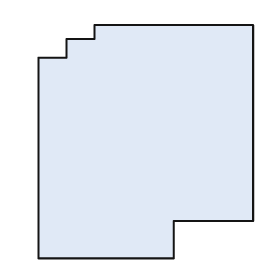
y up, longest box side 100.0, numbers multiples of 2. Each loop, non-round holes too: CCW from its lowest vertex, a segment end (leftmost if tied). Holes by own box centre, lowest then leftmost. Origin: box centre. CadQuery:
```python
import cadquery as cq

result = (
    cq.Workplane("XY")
    .moveTo(-46.0, -50.0)
    .lineTo(12.0, -50.0)
    .lineTo(12.0, -34.0)
    .lineTo(46.0, -34.0)
    .lineTo(46.0, 50.0)
    .lineTo(-22.0, 50.0)
    .lineTo(-22.0, 44.0)
    .lineTo(-34.0, 44.0)
    .lineTo(-34.0, 36.0)
    .lineTo(-46.0, 36.0)
    .close()
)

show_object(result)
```